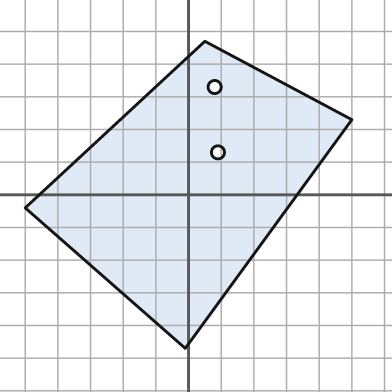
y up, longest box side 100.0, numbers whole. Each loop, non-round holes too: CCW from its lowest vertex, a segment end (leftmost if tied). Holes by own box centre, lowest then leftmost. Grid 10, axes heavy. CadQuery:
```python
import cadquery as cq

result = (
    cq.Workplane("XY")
    .moveTo(-1.0, -47.0)
    .lineTo(50.0, 23.0)
    .lineTo(5.0, 47.0)
    .lineTo(-50.0, -4.0)
    .close()
    .moveTo(9.0, 13.0)
    .circle(2.0)
    .moveTo(8.0, 33.0)
    .circle(2.0)
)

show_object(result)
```